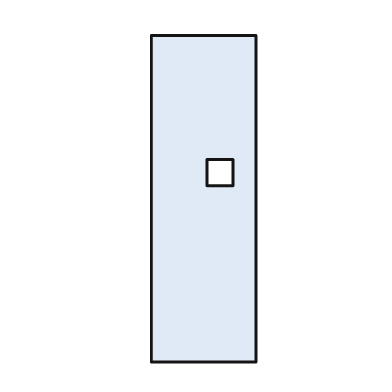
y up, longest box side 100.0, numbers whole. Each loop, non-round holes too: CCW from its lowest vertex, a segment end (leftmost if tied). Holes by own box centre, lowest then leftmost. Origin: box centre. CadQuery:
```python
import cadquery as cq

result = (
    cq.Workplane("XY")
    .moveTo(-16.0, -50.0)
    .lineTo(16.0, -50.0)
    .lineTo(16.0, 50.0)
    .lineTo(-16.0, 50.0)
    .close()
    .moveTo(1.0, 4.0)
    .lineTo(9.0, 4.0)
    .lineTo(9.0, 12.0)
    .lineTo(1.0, 12.0)
    .close()
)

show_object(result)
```